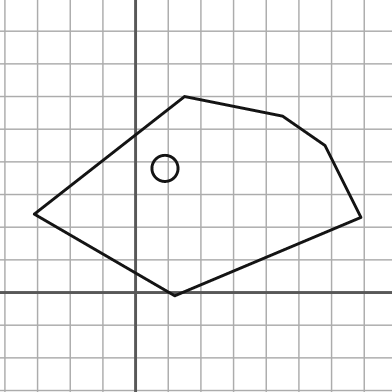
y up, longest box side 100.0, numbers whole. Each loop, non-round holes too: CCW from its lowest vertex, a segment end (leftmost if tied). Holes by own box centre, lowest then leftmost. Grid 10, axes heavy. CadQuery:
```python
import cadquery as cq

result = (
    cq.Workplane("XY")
    .moveTo(12.0, -1.0)
    .lineTo(69.0, 23.0)
    .lineTo(58.0, 45.0)
    .lineTo(45.0, 54.0)
    .lineTo(15.0, 60.0)
    .lineTo(-31.0, 24.0)
    .close()
    .moveTo(9.0, 38.0)
    .circle(4.0)
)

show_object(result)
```